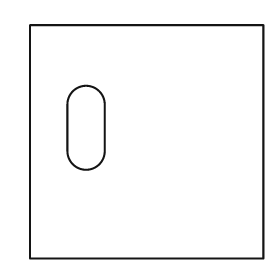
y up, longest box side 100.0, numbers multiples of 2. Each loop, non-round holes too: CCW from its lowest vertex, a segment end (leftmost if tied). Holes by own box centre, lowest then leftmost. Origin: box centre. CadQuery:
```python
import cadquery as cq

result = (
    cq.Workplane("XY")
    .moveTo(-50.0, -50.0)
    .lineTo(50.0, -50.0)
    .lineTo(50.0, 50.0)
    .lineTo(-50.0, 50.0)
    .close()
    .moveTo(-34.0, -4.0)
    .threePointArc((-26.0, -12.0), (-18.0, -4.0))
    .lineTo(-18.0, 16.0)
    .threePointArc((-26.0, 24.0), (-34.0, 16.0))
    .close()
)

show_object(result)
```